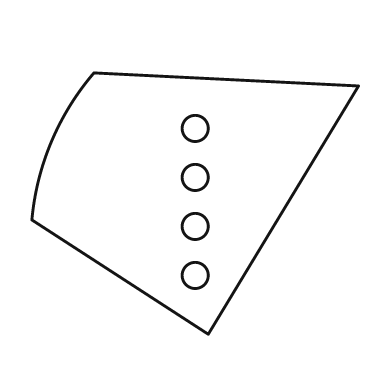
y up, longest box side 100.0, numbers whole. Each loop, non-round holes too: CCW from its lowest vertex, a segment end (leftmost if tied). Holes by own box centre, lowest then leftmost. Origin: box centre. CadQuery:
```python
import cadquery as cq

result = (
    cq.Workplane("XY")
    .moveTo(4.0, -40.0)
    .lineTo(50.0, 36.0)
    .lineTo(-31.0, 40.0)
    .threePointArc((-44.0, 19.0), (-50.0, -5.0))
    .close()
    .moveTo(0.0, -22.0)
    .circle(4.0)
    .moveTo(0.0, -7.0)
    .circle(4.0)
    .moveTo(0.0, 8.0)
    .circle(4.0)
    .moveTo(0.0, 23.0)
    .circle(4.0)
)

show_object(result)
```